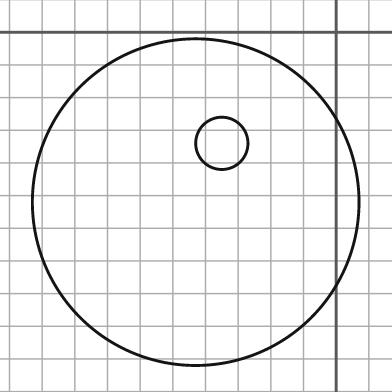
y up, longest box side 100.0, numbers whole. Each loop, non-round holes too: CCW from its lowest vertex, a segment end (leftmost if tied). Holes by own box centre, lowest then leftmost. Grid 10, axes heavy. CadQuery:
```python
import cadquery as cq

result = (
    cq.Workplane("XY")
    .moveTo(-43.0, -52.0)
    .circle(50.0)
    .moveTo(-35.0, -34.0)
    .circle(8.0)
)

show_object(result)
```